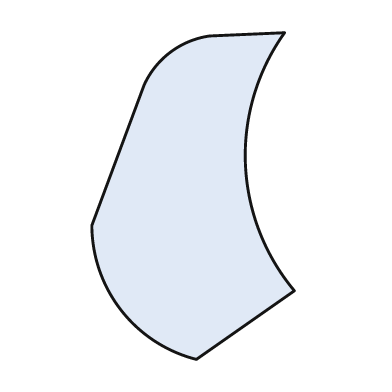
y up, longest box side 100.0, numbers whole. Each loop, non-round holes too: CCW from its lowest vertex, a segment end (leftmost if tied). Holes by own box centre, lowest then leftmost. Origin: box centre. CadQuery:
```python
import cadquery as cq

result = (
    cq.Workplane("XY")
    .moveTo(1.0, -50.0)
    .lineTo(31.0, -29.0)
    .threePointArc((16.0, 10.0), (28.0, 50.0))
    .lineTo(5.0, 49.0)
    .threePointArc((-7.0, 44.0), (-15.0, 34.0))
    .lineTo(-31.0, -9.0)
    .threePointArc((-22.0, -35.0), (1.0, -50.0))
    .close()
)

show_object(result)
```